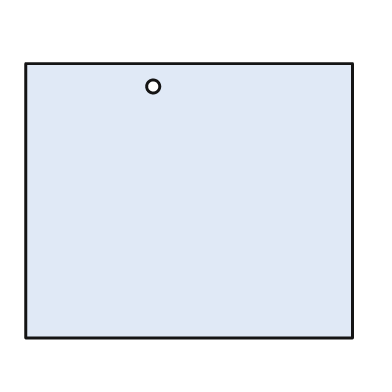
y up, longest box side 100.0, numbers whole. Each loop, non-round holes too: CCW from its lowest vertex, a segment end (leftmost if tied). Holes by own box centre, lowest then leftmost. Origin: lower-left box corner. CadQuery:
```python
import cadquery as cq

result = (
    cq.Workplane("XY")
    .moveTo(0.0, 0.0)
    .lineTo(100.0, 0.0)
    .lineTo(100.0, 84.0)
    .lineTo(0.0, 84.0)
    .close()
    .moveTo(39.0, 77.0)
    .circle(2.0)
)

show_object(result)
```